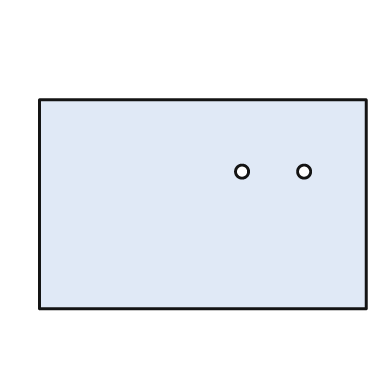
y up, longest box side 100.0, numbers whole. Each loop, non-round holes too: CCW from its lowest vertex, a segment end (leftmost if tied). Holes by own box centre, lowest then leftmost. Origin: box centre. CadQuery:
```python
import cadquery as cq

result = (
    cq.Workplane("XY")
    .moveTo(-50.0, -32.0)
    .lineTo(50.0, -32.0)
    .lineTo(50.0, 32.0)
    .lineTo(-50.0, 32.0)
    .close()
    .moveTo(12.0, 10.0)
    .circle(2.0)
    .moveTo(31.0, 10.0)
    .circle(2.0)
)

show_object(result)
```